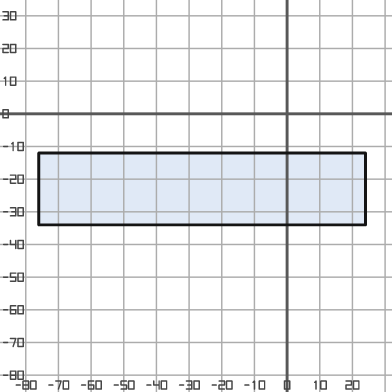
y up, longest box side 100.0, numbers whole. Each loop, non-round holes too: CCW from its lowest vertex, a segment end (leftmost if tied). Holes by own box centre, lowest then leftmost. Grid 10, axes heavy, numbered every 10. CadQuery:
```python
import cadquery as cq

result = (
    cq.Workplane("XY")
    .moveTo(-76.0, -34.0)
    .lineTo(24.0, -34.0)
    .lineTo(24.0, -12.0)
    .lineTo(-76.0, -12.0)
    .close()
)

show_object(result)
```